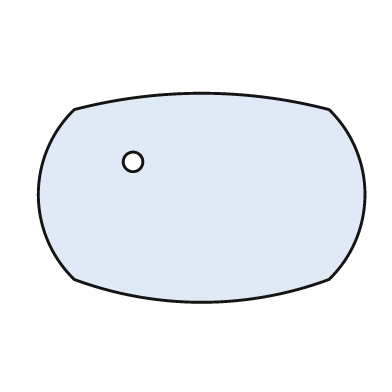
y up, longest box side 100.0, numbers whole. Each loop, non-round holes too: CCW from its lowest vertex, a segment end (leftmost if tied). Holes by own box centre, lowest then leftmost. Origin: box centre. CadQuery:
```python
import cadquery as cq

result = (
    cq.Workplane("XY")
    .moveTo(-39.0, -25.0)
    .threePointArc((0.0, -32.0), (39.0, -25.0))
    .threePointArc((50.0, 1.0), (39.0, 27.0))
    .threePointArc((0.0, 32.0), (-39.0, 27.0))
    .threePointArc((-50.0, 1.0), (-39.0, -25.0))
    .close()
    .moveTo(-21.0, 11.0)
    .circle(3.0)
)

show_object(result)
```